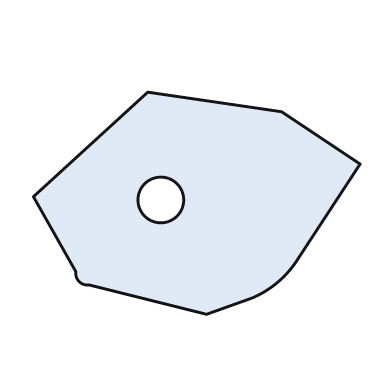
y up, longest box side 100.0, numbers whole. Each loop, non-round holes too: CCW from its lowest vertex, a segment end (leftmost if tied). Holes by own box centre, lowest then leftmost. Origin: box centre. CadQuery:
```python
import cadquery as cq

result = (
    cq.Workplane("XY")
    .moveTo(3.0, -34.0)
    .lineTo(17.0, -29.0)
    .threePointArc((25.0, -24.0), (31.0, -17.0))
    .lineTo(50.0, 12.0)
    .lineTo(26.0, 28.0)
    .lineTo(-15.0, 34.0)
    .lineTo(-50.0, 2.0)
    .lineTo(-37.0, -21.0)
    .threePointArc((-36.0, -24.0), (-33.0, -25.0))
    .close()
    .moveTo(-11.0, 1.0)
    .circle(7.0)
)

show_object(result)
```